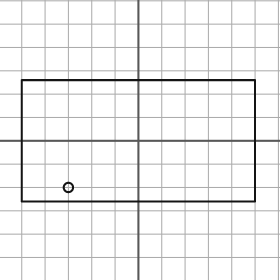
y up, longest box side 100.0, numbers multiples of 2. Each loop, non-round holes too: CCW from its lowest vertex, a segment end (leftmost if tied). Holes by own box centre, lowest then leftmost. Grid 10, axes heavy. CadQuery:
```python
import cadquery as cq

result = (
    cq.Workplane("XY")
    .moveTo(-50.0, -26.0)
    .lineTo(50.0, -26.0)
    .lineTo(50.0, 26.0)
    .lineTo(-50.0, 26.0)
    .close()
    .moveTo(-30.0, -20.0)
    .circle(2.0)
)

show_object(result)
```